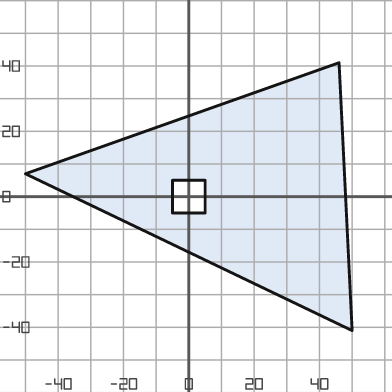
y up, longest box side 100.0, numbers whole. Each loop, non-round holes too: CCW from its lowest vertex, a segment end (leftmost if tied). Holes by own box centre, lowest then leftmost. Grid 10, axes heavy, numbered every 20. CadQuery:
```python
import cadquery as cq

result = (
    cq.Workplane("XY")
    .moveTo(50.0, -41.0)
    .lineTo(46.0, 41.0)
    .lineTo(-50.0, 7.0)
    .close()
    .moveTo(-5.0, -5.0)
    .lineTo(5.0, -5.0)
    .lineTo(5.0, 5.0)
    .lineTo(-5.0, 5.0)
    .close()
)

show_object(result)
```